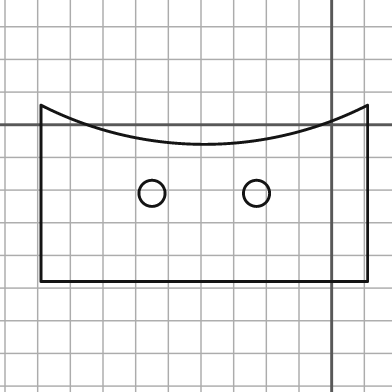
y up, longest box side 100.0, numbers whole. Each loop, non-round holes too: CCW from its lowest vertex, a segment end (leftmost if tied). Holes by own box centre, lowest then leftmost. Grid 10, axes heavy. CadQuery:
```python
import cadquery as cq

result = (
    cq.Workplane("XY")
    .moveTo(-89.0, -48.0)
    .lineTo(11.0, -48.0)
    .lineTo(11.0, 6.0)
    .threePointArc((-39.0, -6.0), (-89.0, 6.0))
    .close()
    .moveTo(-55.0, -21.0)
    .circle(4.0)
    .moveTo(-23.0, -21.0)
    .circle(4.0)
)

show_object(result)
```